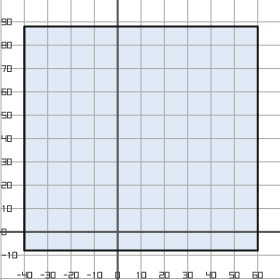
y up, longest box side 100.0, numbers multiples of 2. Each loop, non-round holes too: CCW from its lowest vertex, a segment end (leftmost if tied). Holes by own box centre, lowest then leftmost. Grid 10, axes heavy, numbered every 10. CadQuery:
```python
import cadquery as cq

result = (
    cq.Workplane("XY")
    .moveTo(-40.0, -8.0)
    .lineTo(60.0, -8.0)
    .lineTo(60.0, 88.0)
    .lineTo(-40.0, 88.0)
    .close()
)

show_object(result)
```